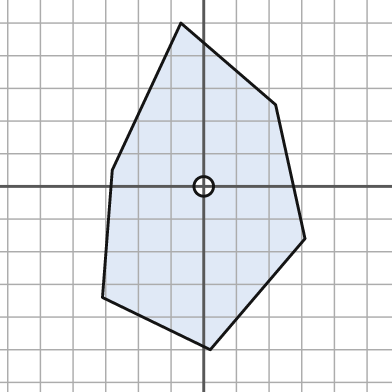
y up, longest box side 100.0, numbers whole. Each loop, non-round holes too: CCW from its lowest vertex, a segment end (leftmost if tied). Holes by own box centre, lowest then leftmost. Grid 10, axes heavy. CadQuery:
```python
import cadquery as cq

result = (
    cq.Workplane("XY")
    .moveTo(2.0, -50.0)
    .lineTo(31.0, -16.0)
    .lineTo(22.0, 25.0)
    .lineTo(-7.0, 50.0)
    .lineTo(-28.0, 5.0)
    .lineTo(-31.0, -34.0)
    .close()
    .moveTo(0.0, 0.0)
    .circle(3.0)
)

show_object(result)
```